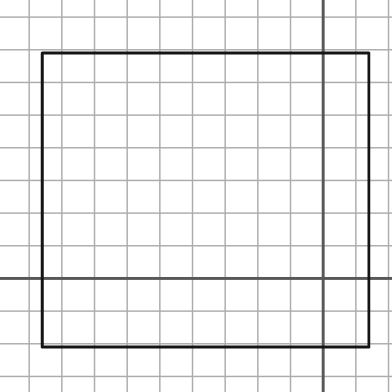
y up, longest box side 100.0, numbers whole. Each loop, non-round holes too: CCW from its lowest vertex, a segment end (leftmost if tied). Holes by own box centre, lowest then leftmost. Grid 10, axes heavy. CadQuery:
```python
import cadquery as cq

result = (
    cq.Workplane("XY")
    .moveTo(-86.0, -21.0)
    .lineTo(14.0, -21.0)
    .lineTo(14.0, 69.0)
    .lineTo(-86.0, 69.0)
    .close()
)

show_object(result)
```